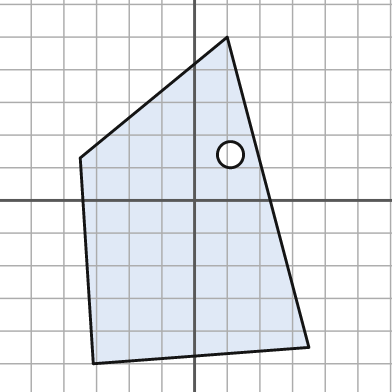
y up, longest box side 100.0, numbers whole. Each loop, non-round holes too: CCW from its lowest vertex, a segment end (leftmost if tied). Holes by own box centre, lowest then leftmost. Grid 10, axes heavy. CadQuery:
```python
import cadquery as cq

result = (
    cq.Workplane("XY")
    .moveTo(-31.0, -50.0)
    .lineTo(35.0, -45.0)
    .lineTo(10.0, 50.0)
    .lineTo(-35.0, 13.0)
    .close()
    .moveTo(11.0, 14.0)
    .circle(4.0)
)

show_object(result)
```